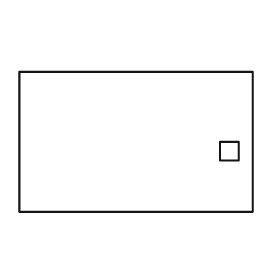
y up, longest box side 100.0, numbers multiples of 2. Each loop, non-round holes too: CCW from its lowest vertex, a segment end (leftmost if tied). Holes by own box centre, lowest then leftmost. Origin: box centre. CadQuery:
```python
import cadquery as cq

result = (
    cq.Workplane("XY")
    .moveTo(-50.0, -30.0)
    .lineTo(50.0, -30.0)
    .lineTo(50.0, 30.0)
    .lineTo(-50.0, 30.0)
    .close()
    .moveTo(36.0, -8.0)
    .lineTo(44.0, -8.0)
    .lineTo(44.0, 0.0)
    .lineTo(36.0, 0.0)
    .close()
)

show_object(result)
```